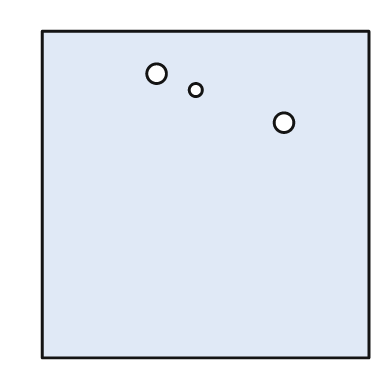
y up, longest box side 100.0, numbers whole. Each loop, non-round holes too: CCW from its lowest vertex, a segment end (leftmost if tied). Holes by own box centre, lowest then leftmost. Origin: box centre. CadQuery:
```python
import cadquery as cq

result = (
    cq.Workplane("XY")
    .moveTo(-50.0, -50.0)
    .lineTo(50.0, -50.0)
    .lineTo(50.0, 50.0)
    .lineTo(-50.0, 50.0)
    .close()
    .moveTo(24.0, 22.0)
    .circle(3.0)
    .moveTo(-3.0, 32.0)
    .circle(2.0)
    .moveTo(-15.0, 37.0)
    .circle(3.0)
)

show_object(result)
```